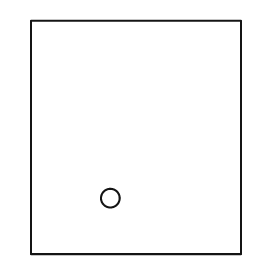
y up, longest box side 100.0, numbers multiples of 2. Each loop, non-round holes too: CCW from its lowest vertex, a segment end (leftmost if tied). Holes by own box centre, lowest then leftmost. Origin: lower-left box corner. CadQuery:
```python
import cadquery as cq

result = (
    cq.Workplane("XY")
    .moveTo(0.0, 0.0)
    .lineTo(90.0, 0.0)
    .lineTo(90.0, 100.0)
    .lineTo(0.0, 100.0)
    .close()
    .moveTo(34.0, 24.0)
    .circle(4.0)
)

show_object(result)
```